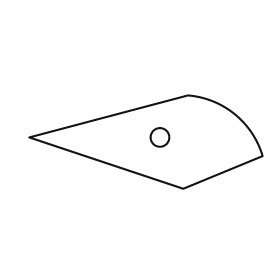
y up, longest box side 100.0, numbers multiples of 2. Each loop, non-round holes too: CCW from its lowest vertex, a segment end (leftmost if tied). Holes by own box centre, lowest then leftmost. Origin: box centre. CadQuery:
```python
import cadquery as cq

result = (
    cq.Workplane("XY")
    .moveTo(16.0, -20.0)
    .lineTo(50.0, -6.0)
    .threePointArc((38.0, 12.0), (18.0, 20.0))
    .lineTo(-50.0, 2.0)
    .close()
    .moveTo(6.0, 2.0)
    .circle(4.0)
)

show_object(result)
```